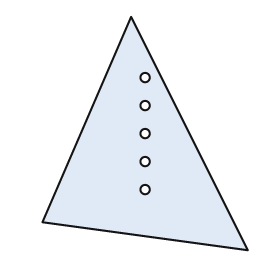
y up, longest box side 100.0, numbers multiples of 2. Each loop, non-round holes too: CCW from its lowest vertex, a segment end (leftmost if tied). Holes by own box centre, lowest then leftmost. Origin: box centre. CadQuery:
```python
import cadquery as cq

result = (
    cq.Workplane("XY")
    .moveTo(44.0, -50.0)
    .lineTo(-6.0, 50.0)
    .lineTo(-44.0, -38.0)
    .close()
    .moveTo(0.0, -24.0)
    .circle(2.0)
    .moveTo(0.0, -12.0)
    .circle(2.0)
    .moveTo(0.0, 0.0)
    .circle(2.0)
    .moveTo(0.0, 12.0)
    .circle(2.0)
    .moveTo(0.0, 24.0)
    .circle(2.0)
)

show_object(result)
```